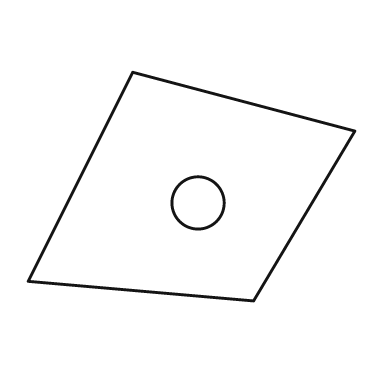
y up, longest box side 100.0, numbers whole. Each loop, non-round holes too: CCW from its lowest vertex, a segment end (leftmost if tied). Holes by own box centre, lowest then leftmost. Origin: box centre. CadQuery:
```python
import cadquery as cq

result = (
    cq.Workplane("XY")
    .moveTo(19.0, -35.0)
    .lineTo(50.0, 17.0)
    .lineTo(-18.0, 35.0)
    .lineTo(-50.0, -29.0)
    .close()
    .moveTo(2.0, -5.0)
    .circle(8.0)
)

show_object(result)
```